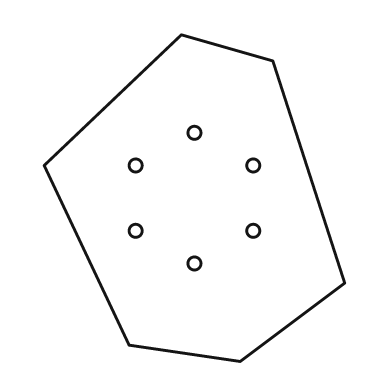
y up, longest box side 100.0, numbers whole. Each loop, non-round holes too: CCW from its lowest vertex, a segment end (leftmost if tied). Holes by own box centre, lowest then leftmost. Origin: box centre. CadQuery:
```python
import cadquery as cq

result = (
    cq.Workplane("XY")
    .moveTo(14.0, -50.0)
    .lineTo(46.0, -26.0)
    .lineTo(24.0, 42.0)
    .lineTo(-4.0, 50.0)
    .lineTo(-46.0, 10.0)
    .lineTo(-20.0, -45.0)
    .close()
    .moveTo(0.0, -20.0)
    .circle(2.0)
    .moveTo(-18.0, -10.0)
    .circle(2.0)
    .moveTo(18.0, -10.0)
    .circle(2.0)
    .moveTo(-18.0, 10.0)
    .circle(2.0)
    .moveTo(18.0, 10.0)
    .circle(2.0)
    .moveTo(0.0, 20.0)
    .circle(2.0)
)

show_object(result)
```